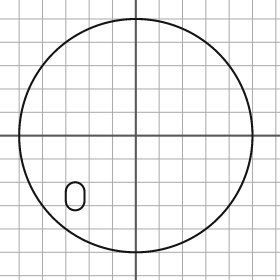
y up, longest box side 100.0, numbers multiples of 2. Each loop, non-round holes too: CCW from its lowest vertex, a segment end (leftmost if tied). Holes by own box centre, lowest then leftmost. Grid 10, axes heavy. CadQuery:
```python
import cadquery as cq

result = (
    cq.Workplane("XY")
    .moveTo(0.0, 0.0)
    .circle(50.0)
    .moveTo(-30.0, -28.0)
    .threePointArc((-26.0, -32.0), (-22.0, -28.0))
    .lineTo(-22.0, -24.0)
    .threePointArc((-26.0, -20.0), (-30.0, -24.0))
    .close()
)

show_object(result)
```